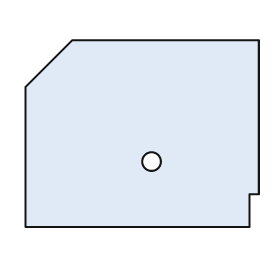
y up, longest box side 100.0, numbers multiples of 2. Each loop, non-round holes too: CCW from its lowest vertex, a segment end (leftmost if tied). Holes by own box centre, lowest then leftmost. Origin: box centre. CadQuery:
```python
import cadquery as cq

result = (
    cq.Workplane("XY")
    .moveTo(-50.0, -40.0)
    .lineTo(46.0, -40.0)
    .lineTo(46.0, -26.0)
    .lineTo(50.0, -26.0)
    .lineTo(50.0, 40.0)
    .lineTo(-30.0, 40.0)
    .lineTo(-50.0, 20.0)
    .close()
    .moveTo(4.0, -12.0)
    .circle(4.0)
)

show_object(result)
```